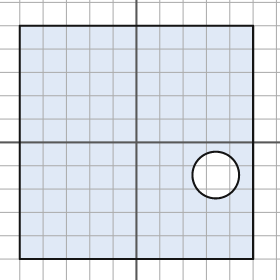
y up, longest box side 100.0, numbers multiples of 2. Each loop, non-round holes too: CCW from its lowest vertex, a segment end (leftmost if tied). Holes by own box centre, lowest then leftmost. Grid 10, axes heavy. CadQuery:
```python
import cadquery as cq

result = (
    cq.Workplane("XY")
    .moveTo(-50.0, -50.0)
    .lineTo(50.0, -50.0)
    .lineTo(50.0, 50.0)
    .lineTo(-50.0, 50.0)
    .close()
    .moveTo(34.0, -14.0)
    .circle(10.0)
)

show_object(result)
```